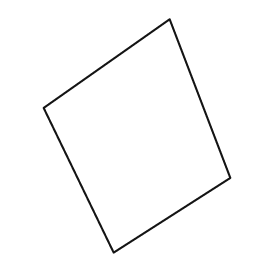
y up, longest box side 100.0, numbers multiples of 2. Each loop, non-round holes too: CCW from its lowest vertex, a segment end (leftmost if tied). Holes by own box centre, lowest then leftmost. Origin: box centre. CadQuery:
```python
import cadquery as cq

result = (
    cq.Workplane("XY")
    .moveTo(-10.0, -50.0)
    .lineTo(40.0, -18.0)
    .lineTo(14.0, 50.0)
    .lineTo(-40.0, 12.0)
    .close()
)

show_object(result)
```